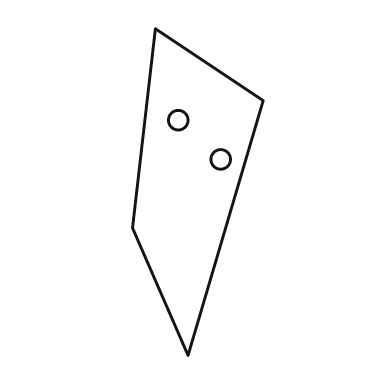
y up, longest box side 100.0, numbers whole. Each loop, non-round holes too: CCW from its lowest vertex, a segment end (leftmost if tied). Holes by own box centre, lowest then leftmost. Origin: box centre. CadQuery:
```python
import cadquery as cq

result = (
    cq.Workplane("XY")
    .moveTo(-3.0, -50.0)
    .lineTo(20.0, 28.0)
    .lineTo(-13.0, 50.0)
    .lineTo(-20.0, -11.0)
    .close()
    .moveTo(7.0, 10.0)
    .circle(3.0)
    .moveTo(-6.0, 22.0)
    .circle(3.0)
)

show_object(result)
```